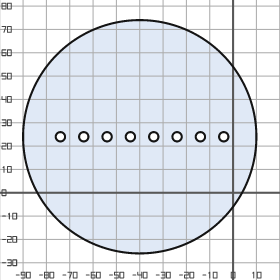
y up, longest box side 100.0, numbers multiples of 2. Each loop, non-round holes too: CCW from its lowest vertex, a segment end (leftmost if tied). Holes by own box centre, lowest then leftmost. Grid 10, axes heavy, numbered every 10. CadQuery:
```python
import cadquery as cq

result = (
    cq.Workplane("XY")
    .moveTo(-40.0, 24.0)
    .circle(50.0)
    .moveTo(-74.0, 24.0)
    .circle(2.0)
    .moveTo(-64.0, 24.0)
    .circle(2.0)
    .moveTo(-54.0, 24.0)
    .circle(2.0)
    .moveTo(-44.0, 24.0)
    .circle(2.0)
    .moveTo(-34.0, 24.0)
    .circle(2.0)
    .moveTo(-24.0, 24.0)
    .circle(2.0)
    .moveTo(-14.0, 24.0)
    .circle(2.0)
    .moveTo(-4.0, 24.0)
    .circle(2.0)
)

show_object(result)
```